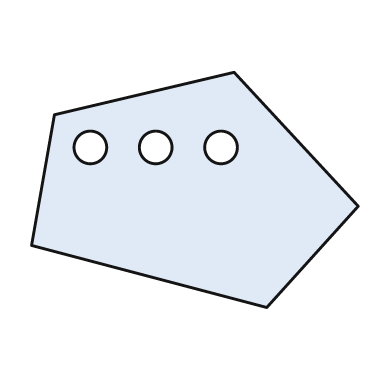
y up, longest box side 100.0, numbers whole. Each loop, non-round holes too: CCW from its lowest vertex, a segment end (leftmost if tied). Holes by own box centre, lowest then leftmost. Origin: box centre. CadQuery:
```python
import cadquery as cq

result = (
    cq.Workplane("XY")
    .moveTo(22.0, -36.0)
    .lineTo(50.0, -5.0)
    .lineTo(12.0, 36.0)
    .lineTo(-43.0, 23.0)
    .lineTo(-50.0, -17.0)
    .close()
    .moveTo(-32.0, 13.0)
    .circle(5.0)
    .moveTo(-12.0, 13.0)
    .circle(5.0)
    .moveTo(8.0, 13.0)
    .circle(5.0)
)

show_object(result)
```